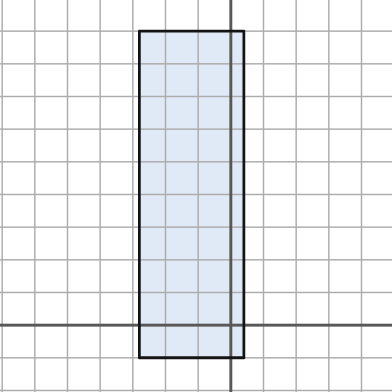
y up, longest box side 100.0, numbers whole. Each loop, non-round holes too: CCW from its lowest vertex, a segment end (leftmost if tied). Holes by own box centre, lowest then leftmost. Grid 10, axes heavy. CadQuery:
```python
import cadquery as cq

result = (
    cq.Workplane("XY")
    .moveTo(-28.0, -10.0)
    .lineTo(4.0, -10.0)
    .lineTo(4.0, 90.0)
    .lineTo(-28.0, 90.0)
    .close()
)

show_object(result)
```